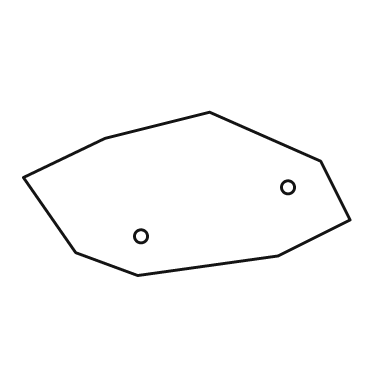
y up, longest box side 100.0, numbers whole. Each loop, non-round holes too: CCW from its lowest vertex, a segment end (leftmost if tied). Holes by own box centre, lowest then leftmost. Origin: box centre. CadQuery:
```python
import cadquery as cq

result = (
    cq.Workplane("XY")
    .moveTo(-15.0, -25.0)
    .lineTo(28.0, -19.0)
    .lineTo(50.0, -8.0)
    .lineTo(41.0, 10.0)
    .lineTo(7.0, 25.0)
    .lineTo(-25.0, 17.0)
    .lineTo(-50.0, 5.0)
    .lineTo(-34.0, -18.0)
    .close()
    .moveTo(-14.0, -13.0)
    .circle(2.0)
    .moveTo(31.0, 2.0)
    .circle(2.0)
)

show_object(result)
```